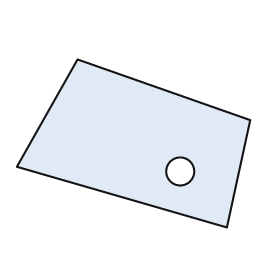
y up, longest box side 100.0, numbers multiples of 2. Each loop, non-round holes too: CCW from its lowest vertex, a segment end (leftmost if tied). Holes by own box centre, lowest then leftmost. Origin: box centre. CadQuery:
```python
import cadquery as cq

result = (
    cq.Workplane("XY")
    .moveTo(40.0, -36.0)
    .lineTo(50.0, 10.0)
    .lineTo(-24.0, 36.0)
    .lineTo(-50.0, -10.0)
    .close()
    .moveTo(20.0, -12.0)
    .circle(6.0)
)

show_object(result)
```